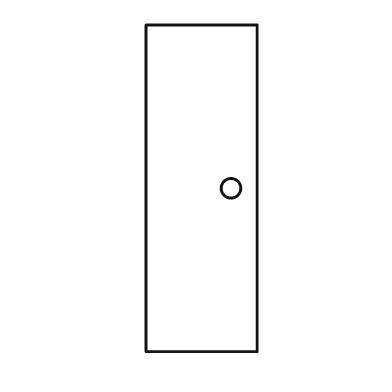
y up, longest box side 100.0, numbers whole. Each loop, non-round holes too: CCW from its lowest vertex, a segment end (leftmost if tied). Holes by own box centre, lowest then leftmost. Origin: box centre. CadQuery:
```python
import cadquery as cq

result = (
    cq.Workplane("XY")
    .moveTo(-17.0, -50.0)
    .lineTo(17.0, -50.0)
    .lineTo(17.0, 50.0)
    .lineTo(-17.0, 50.0)
    .close()
    .moveTo(9.0, 0.0)
    .circle(3.0)
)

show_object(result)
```